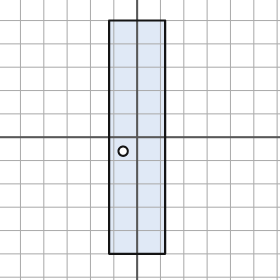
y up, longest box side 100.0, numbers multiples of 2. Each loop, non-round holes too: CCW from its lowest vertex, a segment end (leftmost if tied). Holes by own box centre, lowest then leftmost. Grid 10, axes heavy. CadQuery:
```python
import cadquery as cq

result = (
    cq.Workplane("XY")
    .moveTo(-12.0, -50.0)
    .lineTo(12.0, -50.0)
    .lineTo(12.0, 50.0)
    .lineTo(-12.0, 50.0)
    .close()
    .moveTo(-6.0, -6.0)
    .circle(2.0)
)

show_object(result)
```